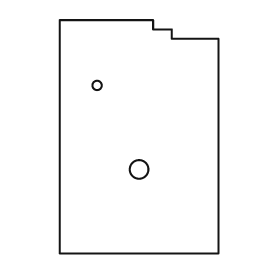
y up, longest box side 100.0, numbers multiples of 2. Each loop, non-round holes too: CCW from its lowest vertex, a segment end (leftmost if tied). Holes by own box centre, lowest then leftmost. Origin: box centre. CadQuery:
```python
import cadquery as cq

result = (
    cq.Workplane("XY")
    .moveTo(-34.0, -50.0)
    .lineTo(34.0, -50.0)
    .lineTo(34.0, 42.0)
    .lineTo(14.0, 42.0)
    .lineTo(14.0, 46.0)
    .lineTo(6.0, 46.0)
    .lineTo(6.0, 50.0)
    .lineTo(-34.0, 50.0)
    .close()
    .moveTo(0.0, -14.0)
    .circle(4.0)
    .moveTo(-18.0, 22.0)
    .circle(2.0)
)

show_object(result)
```